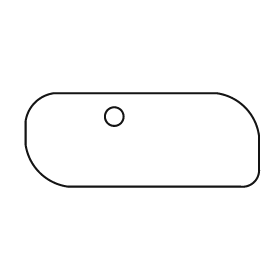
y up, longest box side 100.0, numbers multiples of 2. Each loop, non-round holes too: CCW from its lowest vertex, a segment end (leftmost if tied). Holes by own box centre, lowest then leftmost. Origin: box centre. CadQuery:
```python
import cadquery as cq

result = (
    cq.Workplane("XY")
    .moveTo(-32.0, -20.0)
    .lineTo(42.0, -20.0)
    .threePointArc((48.0, -18.0), (50.0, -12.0))
    .lineTo(50.0, 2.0)
    .threePointArc((44.0, 14.0), (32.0, 20.0))
    .lineTo(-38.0, 20.0)
    .threePointArc((-46.0, 16.0), (-50.0, 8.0))
    .lineTo(-50.0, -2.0)
    .threePointArc((-44.0, -14.0), (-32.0, -20.0))
    .close()
    .moveTo(-12.0, 10.0)
    .circle(4.0)
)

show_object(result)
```